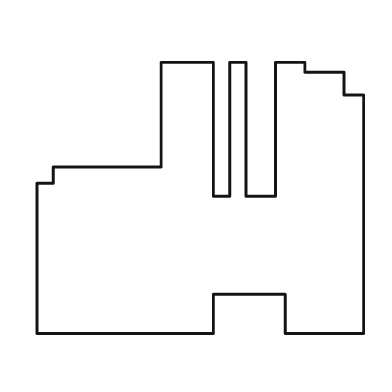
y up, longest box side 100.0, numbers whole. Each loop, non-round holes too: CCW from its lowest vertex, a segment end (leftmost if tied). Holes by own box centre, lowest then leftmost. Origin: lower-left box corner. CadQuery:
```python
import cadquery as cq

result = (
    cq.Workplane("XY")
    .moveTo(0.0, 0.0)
    .lineTo(54.0, 0.0)
    .lineTo(54.0, 12.0)
    .lineTo(76.0, 12.0)
    .lineTo(76.0, 0.0)
    .lineTo(100.0, 0.0)
    .lineTo(100.0, 73.0)
    .lineTo(94.0, 73.0)
    .lineTo(94.0, 80.0)
    .lineTo(82.0, 80.0)
    .lineTo(82.0, 83.0)
    .lineTo(73.0, 83.0)
    .lineTo(73.0, 42.0)
    .lineTo(64.0, 42.0)
    .lineTo(64.0, 83.0)
    .lineTo(59.0, 83.0)
    .lineTo(59.0, 42.0)
    .lineTo(54.0, 42.0)
    .lineTo(54.0, 83.0)
    .lineTo(38.0, 83.0)
    .lineTo(38.0, 51.0)
    .lineTo(5.0, 51.0)
    .lineTo(5.0, 46.0)
    .lineTo(0.0, 46.0)
    .close()
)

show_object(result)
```